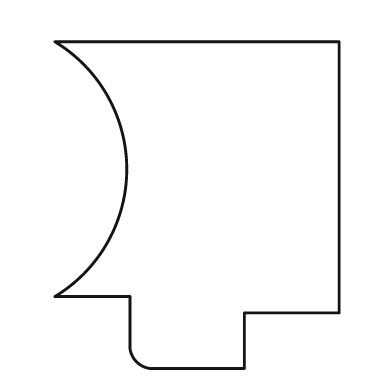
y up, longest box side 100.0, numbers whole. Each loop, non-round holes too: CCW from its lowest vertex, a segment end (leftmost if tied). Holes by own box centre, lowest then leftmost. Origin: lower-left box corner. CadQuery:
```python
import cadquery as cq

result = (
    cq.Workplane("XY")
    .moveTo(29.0, 0.0)
    .lineTo(58.0, 0.0)
    .lineTo(58.0, 17.0)
    .lineTo(87.0, 17.0)
    .lineTo(87.0, 100.0)
    .lineTo(0.0, 100.0)
    .threePointArc((22.0, 61.0), (0.0, 22.0))
    .lineTo(23.0, 22.0)
    .lineTo(23.0, 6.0)
    .threePointArc((25.0, 2.0), (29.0, 0.0))
    .close()
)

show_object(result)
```